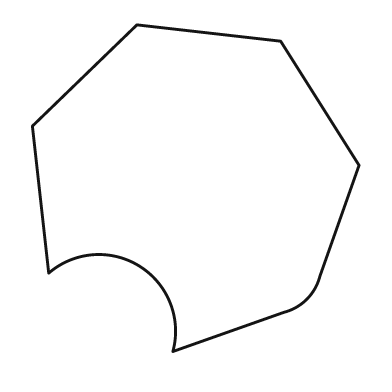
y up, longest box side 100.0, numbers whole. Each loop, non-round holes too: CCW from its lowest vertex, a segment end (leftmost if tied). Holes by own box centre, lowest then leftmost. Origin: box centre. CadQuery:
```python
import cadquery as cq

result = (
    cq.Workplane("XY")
    .moveTo(-7.0, -50.0)
    .lineTo(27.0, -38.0)
    .threePointArc((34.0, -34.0), (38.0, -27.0))
    .lineTo(50.0, 7.0)
    .lineTo(26.0, 45.0)
    .lineTo(-18.0, 50.0)
    .lineTo(-50.0, 19.0)
    .lineTo(-45.0, -26.0)
    .threePointArc((-17.0, -24.0), (-7.0, -50.0))
    .close()
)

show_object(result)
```